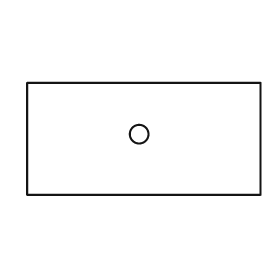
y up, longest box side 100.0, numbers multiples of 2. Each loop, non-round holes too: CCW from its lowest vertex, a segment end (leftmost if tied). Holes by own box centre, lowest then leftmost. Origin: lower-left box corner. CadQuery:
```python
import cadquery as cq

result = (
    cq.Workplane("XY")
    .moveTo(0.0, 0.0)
    .lineTo(100.0, 0.0)
    .lineTo(100.0, 48.0)
    .lineTo(0.0, 48.0)
    .close()
    .moveTo(48.0, 26.0)
    .circle(4.0)
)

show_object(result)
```